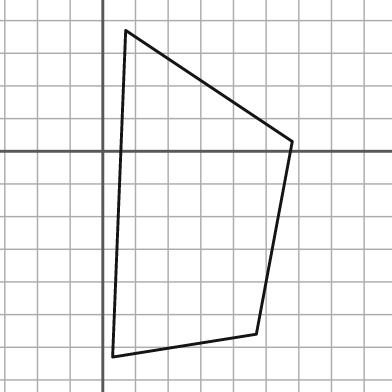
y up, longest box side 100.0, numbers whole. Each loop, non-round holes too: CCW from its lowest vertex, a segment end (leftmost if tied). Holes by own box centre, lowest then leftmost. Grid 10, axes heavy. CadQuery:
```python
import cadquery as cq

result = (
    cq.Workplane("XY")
    .moveTo(3.0, -63.0)
    .lineTo(47.0, -56.0)
    .lineTo(58.0, 3.0)
    .lineTo(7.0, 37.0)
    .close()
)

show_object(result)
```